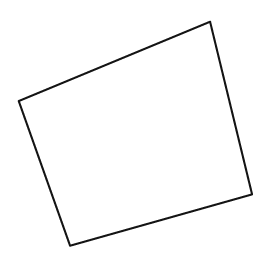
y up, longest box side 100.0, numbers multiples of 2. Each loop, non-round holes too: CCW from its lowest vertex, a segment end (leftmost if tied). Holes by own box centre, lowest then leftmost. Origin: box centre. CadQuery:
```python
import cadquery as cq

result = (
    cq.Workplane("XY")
    .moveTo(-28.0, -48.0)
    .lineTo(50.0, -26.0)
    .lineTo(32.0, 48.0)
    .lineTo(-50.0, 14.0)
    .close()
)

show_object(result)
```